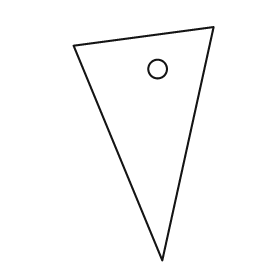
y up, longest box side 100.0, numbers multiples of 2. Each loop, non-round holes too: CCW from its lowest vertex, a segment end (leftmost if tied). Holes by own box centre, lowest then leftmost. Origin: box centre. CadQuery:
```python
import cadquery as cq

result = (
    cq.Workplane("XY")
    .moveTo(8.0, -50.0)
    .lineTo(30.0, 50.0)
    .lineTo(-30.0, 42.0)
    .close()
    .moveTo(6.0, 32.0)
    .circle(4.0)
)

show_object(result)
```